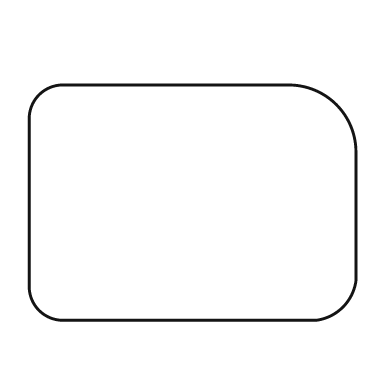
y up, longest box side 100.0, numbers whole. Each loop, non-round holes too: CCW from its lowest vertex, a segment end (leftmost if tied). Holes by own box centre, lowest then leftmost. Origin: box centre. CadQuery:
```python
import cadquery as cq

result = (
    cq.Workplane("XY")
    .moveTo(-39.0, -36.0)
    .lineTo(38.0, -36.0)
    .threePointArc((46.0, -32.0), (50.0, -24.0))
    .lineTo(50.0, 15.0)
    .threePointArc((44.0, 30.0), (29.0, 36.0))
    .lineTo(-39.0, 36.0)
    .threePointArc((-47.0, 33.0), (-50.0, 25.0))
    .lineTo(-50.0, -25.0)
    .threePointArc((-47.0, -33.0), (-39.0, -36.0))
    .close()
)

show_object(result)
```